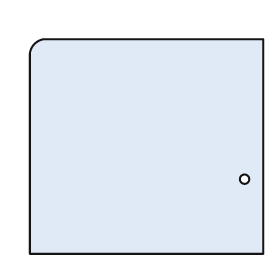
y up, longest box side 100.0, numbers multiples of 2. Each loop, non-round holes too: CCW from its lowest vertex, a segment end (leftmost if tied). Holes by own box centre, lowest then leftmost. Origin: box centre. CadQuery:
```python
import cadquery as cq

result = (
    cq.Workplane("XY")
    .moveTo(-50.0, -46.0)
    .lineTo(50.0, -46.0)
    .lineTo(50.0, 46.0)
    .lineTo(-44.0, 46.0)
    .threePointArc((-48.0, 44.0), (-50.0, 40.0))
    .close()
    .moveTo(42.0, -14.0)
    .circle(2.0)
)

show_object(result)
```